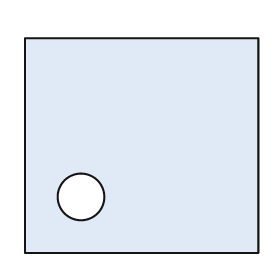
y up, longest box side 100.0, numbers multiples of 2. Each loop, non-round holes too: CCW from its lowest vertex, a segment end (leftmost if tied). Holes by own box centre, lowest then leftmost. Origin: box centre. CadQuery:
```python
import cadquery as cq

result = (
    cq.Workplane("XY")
    .moveTo(-50.0, -46.0)
    .lineTo(50.0, -46.0)
    .lineTo(50.0, 46.0)
    .lineTo(-50.0, 46.0)
    .close()
    .moveTo(-26.0, -22.0)
    .circle(10.0)
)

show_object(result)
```